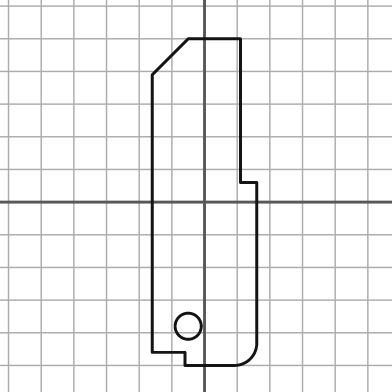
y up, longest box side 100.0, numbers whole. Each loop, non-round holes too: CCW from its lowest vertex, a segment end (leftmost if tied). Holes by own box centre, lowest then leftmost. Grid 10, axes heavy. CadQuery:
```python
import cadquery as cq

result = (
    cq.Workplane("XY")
    .moveTo(-6.0, -50.0)
    .lineTo(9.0, -50.0)
    .threePointArc((14.0, -48.0), (16.0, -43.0))
    .lineTo(16.0, 6.0)
    .lineTo(11.0, 6.0)
    .lineTo(11.0, 50.0)
    .lineTo(-5.0, 50.0)
    .lineTo(-16.0, 39.0)
    .lineTo(-16.0, -46.0)
    .lineTo(-6.0, -46.0)
    .close()
    .moveTo(-5.0, -38.0)
    .circle(4.0)
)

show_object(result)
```